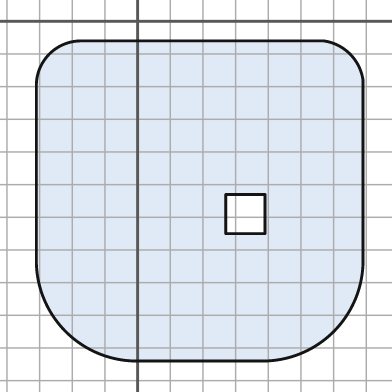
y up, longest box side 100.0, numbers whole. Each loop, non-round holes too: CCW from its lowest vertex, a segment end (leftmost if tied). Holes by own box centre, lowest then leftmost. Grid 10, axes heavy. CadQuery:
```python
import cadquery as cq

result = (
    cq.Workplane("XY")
    .moveTo(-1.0, -104.0)
    .lineTo(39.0, -104.0)
    .threePointArc((60.0, -95.0), (69.0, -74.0))
    .lineTo(69.0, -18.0)
    .threePointArc((65.0, -10.0), (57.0, -6.0))
    .lineTo(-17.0, -6.0)
    .threePointArc((-27.0, -10.0), (-31.0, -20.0))
    .lineTo(-31.0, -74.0)
    .threePointArc((-22.0, -95.0), (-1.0, -104.0))
    .close()
    .moveTo(27.0, -65.0)
    .lineTo(39.0, -65.0)
    .lineTo(39.0, -53.0)
    .lineTo(27.0, -53.0)
    .close()
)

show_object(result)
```